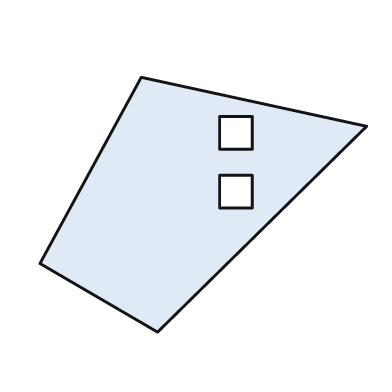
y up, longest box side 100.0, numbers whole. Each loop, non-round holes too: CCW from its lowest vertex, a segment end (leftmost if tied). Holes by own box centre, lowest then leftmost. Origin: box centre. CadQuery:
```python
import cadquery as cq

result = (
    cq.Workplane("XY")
    .moveTo(-14.0, -39.0)
    .lineTo(50.0, 24.0)
    .lineTo(-19.0, 39.0)
    .lineTo(-50.0, -18.0)
    .close()
    .moveTo(5.0, -1.0)
    .lineTo(15.0, -1.0)
    .lineTo(15.0, 9.0)
    .lineTo(5.0, 9.0)
    .close()
    .moveTo(5.0, 17.0)
    .lineTo(15.0, 17.0)
    .lineTo(15.0, 27.0)
    .lineTo(5.0, 27.0)
    .close()
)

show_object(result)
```